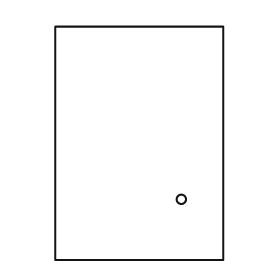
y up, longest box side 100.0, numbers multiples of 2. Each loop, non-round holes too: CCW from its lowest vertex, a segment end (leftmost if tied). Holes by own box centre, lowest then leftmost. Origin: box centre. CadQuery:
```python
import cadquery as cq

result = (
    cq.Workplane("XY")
    .moveTo(-36.0, -50.0)
    .lineTo(36.0, -50.0)
    .lineTo(36.0, 50.0)
    .lineTo(-36.0, 50.0)
    .close()
    .moveTo(18.0, -24.0)
    .circle(2.0)
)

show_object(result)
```